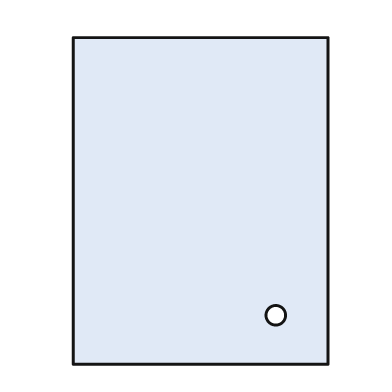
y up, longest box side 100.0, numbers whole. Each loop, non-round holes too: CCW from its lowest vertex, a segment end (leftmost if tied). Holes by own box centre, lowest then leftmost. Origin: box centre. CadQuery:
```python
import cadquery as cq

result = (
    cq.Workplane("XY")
    .moveTo(-39.0, -50.0)
    .lineTo(39.0, -50.0)
    .lineTo(39.0, 50.0)
    .lineTo(-39.0, 50.0)
    .close()
    .moveTo(23.0, -35.0)
    .circle(3.0)
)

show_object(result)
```